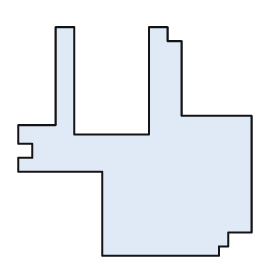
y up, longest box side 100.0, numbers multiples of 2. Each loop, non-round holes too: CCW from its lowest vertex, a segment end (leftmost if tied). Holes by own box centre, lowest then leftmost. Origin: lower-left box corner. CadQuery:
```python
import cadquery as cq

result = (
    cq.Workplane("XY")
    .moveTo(36.0, 0.0)
    .lineTo(86.0, 0.0)
    .lineTo(86.0, 4.0)
    .lineTo(90.0, 4.0)
    .lineTo(90.0, 10.0)
    .lineTo(100.0, 10.0)
    .lineTo(100.0, 60.0)
    .lineTo(70.0, 60.0)
    .lineTo(70.0, 92.0)
    .lineTo(64.0, 92.0)
    .lineTo(64.0, 98.0)
    .lineTo(56.0, 98.0)
    .lineTo(56.0, 52.0)
    .lineTo(24.0, 52.0)
    .lineTo(24.0, 98.0)
    .lineTo(16.0, 98.0)
    .lineTo(16.0, 56.0)
    .lineTo(0.0, 56.0)
    .lineTo(0.0, 48.0)
    .lineTo(6.0, 48.0)
    .lineTo(6.0, 42.0)
    .lineTo(0.0, 42.0)
    .lineTo(0.0, 36.0)
    .lineTo(36.0, 36.0)
    .close()
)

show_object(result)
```